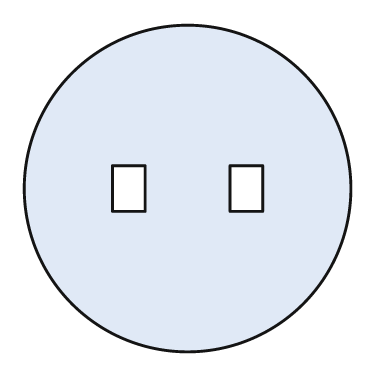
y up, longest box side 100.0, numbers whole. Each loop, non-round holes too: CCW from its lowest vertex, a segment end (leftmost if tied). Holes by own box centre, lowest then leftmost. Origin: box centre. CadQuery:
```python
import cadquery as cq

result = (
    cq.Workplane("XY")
    .moveTo(0.0, 0.0)
    .circle(50.0)
    .moveTo(-23.0, -7.0)
    .lineTo(-13.0, -7.0)
    .lineTo(-13.0, 7.0)
    .lineTo(-23.0, 7.0)
    .close()
    .moveTo(13.0, -7.0)
    .lineTo(23.0, -7.0)
    .lineTo(23.0, 7.0)
    .lineTo(13.0, 7.0)
    .close()
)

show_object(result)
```